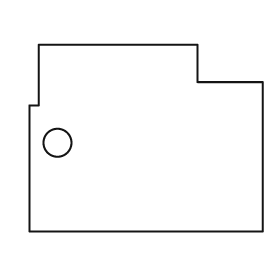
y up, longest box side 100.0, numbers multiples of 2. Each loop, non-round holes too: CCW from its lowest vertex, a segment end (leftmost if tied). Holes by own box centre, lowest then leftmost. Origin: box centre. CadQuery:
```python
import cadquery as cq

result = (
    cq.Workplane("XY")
    .moveTo(-50.0, -40.0)
    .lineTo(50.0, -40.0)
    .lineTo(50.0, 24.0)
    .lineTo(22.0, 24.0)
    .lineTo(22.0, 40.0)
    .lineTo(-46.0, 40.0)
    .lineTo(-46.0, 14.0)
    .lineTo(-50.0, 14.0)
    .close()
    .moveTo(-38.0, -2.0)
    .circle(6.0)
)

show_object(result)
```